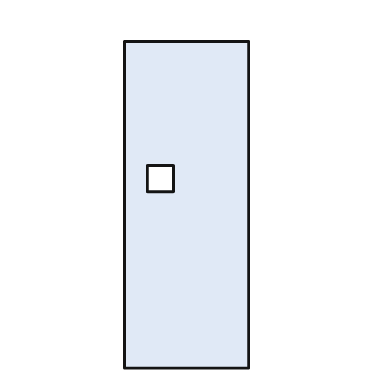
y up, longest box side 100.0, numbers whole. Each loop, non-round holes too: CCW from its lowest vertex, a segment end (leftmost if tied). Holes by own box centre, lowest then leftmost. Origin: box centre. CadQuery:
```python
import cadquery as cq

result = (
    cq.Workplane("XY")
    .moveTo(-19.0, -50.0)
    .lineTo(19.0, -50.0)
    .lineTo(19.0, 50.0)
    .lineTo(-19.0, 50.0)
    .close()
    .moveTo(-12.0, 4.0)
    .lineTo(-4.0, 4.0)
    .lineTo(-4.0, 12.0)
    .lineTo(-12.0, 12.0)
    .close()
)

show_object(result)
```